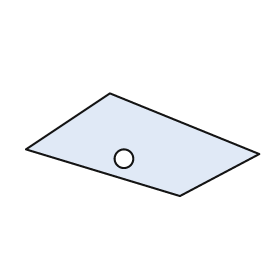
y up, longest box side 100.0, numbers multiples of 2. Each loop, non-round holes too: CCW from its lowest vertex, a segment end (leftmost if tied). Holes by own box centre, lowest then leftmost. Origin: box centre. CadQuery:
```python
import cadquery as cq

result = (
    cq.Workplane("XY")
    .moveTo(16.0, -22.0)
    .lineTo(50.0, -4.0)
    .lineTo(-14.0, 22.0)
    .lineTo(-50.0, -2.0)
    .close()
    .moveTo(-8.0, -6.0)
    .circle(4.0)
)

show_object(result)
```